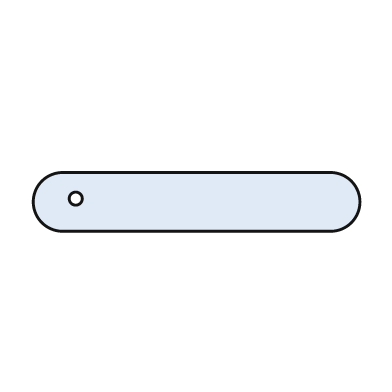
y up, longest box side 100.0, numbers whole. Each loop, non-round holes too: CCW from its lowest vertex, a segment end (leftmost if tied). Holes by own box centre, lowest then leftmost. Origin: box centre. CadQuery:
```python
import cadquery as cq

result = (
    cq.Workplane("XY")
    .moveTo(-41.0, -9.0)
    .lineTo(41.0, -9.0)
    .threePointArc((50.0, 0.0), (41.0, 9.0))
    .lineTo(-41.0, 9.0)
    .threePointArc((-50.0, 0.0), (-41.0, -9.0))
    .close()
    .moveTo(-37.0, 1.0)
    .circle(2.0)
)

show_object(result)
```